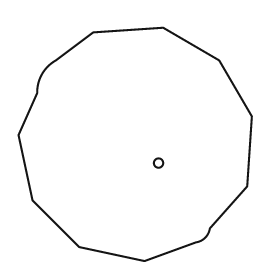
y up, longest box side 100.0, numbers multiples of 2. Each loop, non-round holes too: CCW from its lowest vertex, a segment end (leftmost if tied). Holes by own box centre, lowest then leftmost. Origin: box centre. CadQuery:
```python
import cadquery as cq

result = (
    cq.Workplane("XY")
    .moveTo(4.0, -50.0)
    .lineTo(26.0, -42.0)
    .threePointArc((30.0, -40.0), (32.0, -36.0))
    .lineTo(48.0, -18.0)
    .lineTo(50.0, 12.0)
    .lineTo(36.0, 36.0)
    .lineTo(12.0, 50.0)
    .lineTo(-18.0, 48.0)
    .lineTo(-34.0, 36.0)
    .threePointArc((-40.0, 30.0), (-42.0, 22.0))
    .lineTo(-50.0, 4.0)
    .lineTo(-44.0, -24.0)
    .lineTo(-24.0, -44.0)
    .close()
    .moveTo(10.0, -8.0)
    .circle(2.0)
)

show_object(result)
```